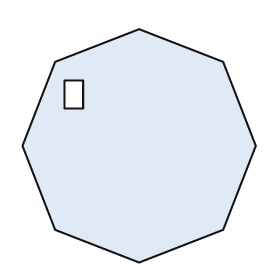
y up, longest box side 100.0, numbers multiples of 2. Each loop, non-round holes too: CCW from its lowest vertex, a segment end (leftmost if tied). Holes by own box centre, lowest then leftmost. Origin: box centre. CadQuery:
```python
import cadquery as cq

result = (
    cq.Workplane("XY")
    .moveTo(0.0, -50.0)
    .lineTo(36.0, -36.0)
    .lineTo(50.0, 0.0)
    .lineTo(36.0, 36.0)
    .lineTo(0.0, 50.0)
    .lineTo(-36.0, 36.0)
    .lineTo(-50.0, 0.0)
    .lineTo(-36.0, -36.0)
    .close()
    .moveTo(-32.0, 16.0)
    .lineTo(-24.0, 16.0)
    .lineTo(-24.0, 28.0)
    .lineTo(-32.0, 28.0)
    .close()
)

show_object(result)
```